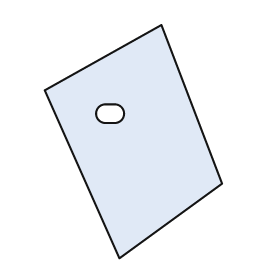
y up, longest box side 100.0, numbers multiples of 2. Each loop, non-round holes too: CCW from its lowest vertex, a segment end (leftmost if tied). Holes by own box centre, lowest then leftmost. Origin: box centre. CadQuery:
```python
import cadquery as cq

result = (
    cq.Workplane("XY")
    .moveTo(-6.0, -50.0)
    .lineTo(38.0, -18.0)
    .lineTo(12.0, 50.0)
    .lineTo(-38.0, 22.0)
    .close()
    .moveTo(-12.0, 8.0)
    .lineTo(-8.0, 8.0)
    .threePointArc((-4.0, 12.0), (-8.0, 16.0))
    .lineTo(-12.0, 16.0)
    .threePointArc((-16.0, 12.0), (-12.0, 8.0))
    .close()
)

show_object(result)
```